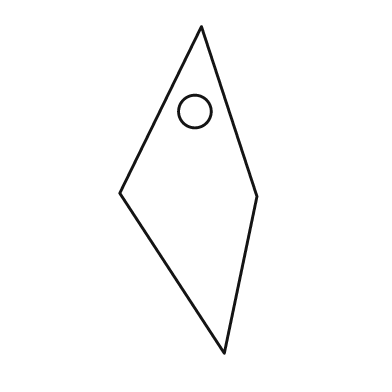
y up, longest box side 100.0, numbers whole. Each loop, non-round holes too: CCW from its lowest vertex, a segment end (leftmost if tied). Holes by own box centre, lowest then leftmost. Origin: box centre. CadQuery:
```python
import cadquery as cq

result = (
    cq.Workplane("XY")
    .moveTo(11.0, -50.0)
    .lineTo(21.0, -2.0)
    .lineTo(4.0, 50.0)
    .lineTo(-21.0, -1.0)
    .close()
    .moveTo(2.0, 24.0)
    .circle(5.0)
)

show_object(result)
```